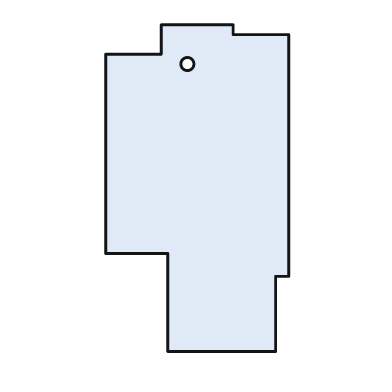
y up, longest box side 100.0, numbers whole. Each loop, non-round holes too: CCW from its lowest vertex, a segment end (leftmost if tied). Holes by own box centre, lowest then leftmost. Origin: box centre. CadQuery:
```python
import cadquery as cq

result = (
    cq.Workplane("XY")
    .moveTo(-9.0, -50.0)
    .lineTo(24.0, -50.0)
    .lineTo(24.0, -27.0)
    .lineTo(28.0, -27.0)
    .lineTo(28.0, 47.0)
    .lineTo(11.0, 47.0)
    .lineTo(11.0, 50.0)
    .lineTo(-11.0, 50.0)
    .lineTo(-11.0, 41.0)
    .lineTo(-28.0, 41.0)
    .lineTo(-28.0, -20.0)
    .lineTo(-9.0, -20.0)
    .close()
    .moveTo(-3.0, 38.0)
    .circle(2.0)
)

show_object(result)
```